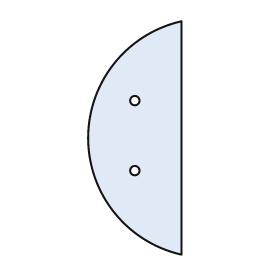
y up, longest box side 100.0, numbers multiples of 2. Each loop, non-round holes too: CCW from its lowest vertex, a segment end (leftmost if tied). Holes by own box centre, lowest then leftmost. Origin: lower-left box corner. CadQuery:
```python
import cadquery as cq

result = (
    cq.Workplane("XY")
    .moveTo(40.0, 0.0)
    .lineTo(40.0, 100.0)
    .threePointArc((0.0, 50.0), (40.0, 0.0))
    .close()
    .moveTo(20.0, 36.0)
    .circle(2.0)
    .moveTo(20.0, 66.0)
    .circle(2.0)
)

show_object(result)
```